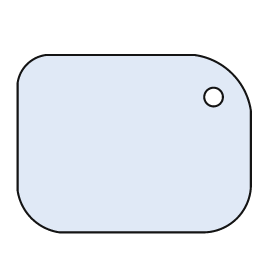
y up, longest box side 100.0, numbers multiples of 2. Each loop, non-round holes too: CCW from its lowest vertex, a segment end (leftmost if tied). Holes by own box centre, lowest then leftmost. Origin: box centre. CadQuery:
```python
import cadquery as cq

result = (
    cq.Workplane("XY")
    .moveTo(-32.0, -38.0)
    .lineTo(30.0, -38.0)
    .threePointArc((44.0, -32.0), (50.0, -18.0))
    .lineTo(50.0, 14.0)
    .threePointArc((42.0, 30.0), (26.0, 38.0))
    .lineTo(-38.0, 38.0)
    .threePointArc((-46.0, 34.0), (-50.0, 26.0))
    .lineTo(-50.0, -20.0)
    .threePointArc((-44.0, -32.0), (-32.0, -38.0))
    .close()
    .moveTo(34.0, 20.0)
    .circle(4.0)
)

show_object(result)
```